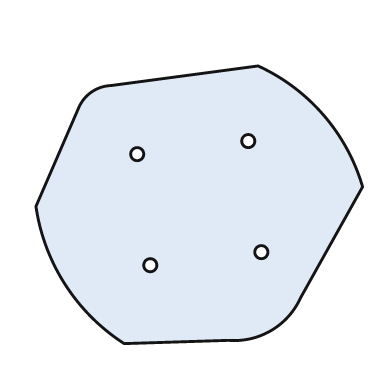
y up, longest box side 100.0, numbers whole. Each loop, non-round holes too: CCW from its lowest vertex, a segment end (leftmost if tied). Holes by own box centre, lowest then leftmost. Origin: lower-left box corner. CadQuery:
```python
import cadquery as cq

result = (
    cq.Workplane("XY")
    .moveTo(27.0, 0.0)
    .lineTo(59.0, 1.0)
    .threePointArc((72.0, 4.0), (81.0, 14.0))
    .lineTo(100.0, 48.0)
    .threePointArc((88.0, 70.0), (68.0, 85.0))
    .lineTo(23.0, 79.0)
    .threePointArc((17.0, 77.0), (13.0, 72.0))
    .lineTo(0.0, 42.0)
    .threePointArc((9.0, 18.0), (27.0, 0.0))
    .close()
    .moveTo(35.0, 24.0)
    .circle(2.0)
    .moveTo(69.0, 28.0)
    .circle(2.0)
    .moveTo(31.0, 58.0)
    .circle(2.0)
    .moveTo(65.0, 62.0)
    .circle(2.0)
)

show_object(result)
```